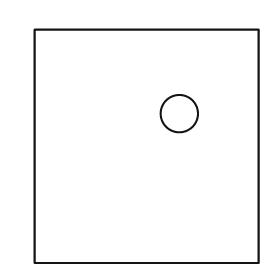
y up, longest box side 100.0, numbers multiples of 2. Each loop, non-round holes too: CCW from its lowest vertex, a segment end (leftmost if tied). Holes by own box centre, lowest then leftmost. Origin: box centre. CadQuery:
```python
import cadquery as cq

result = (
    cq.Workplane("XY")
    .moveTo(-48.0, -50.0)
    .lineTo(48.0, -50.0)
    .lineTo(48.0, 50.0)
    .lineTo(-48.0, 50.0)
    .close()
    .moveTo(14.0, 14.0)
    .circle(8.0)
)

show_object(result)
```